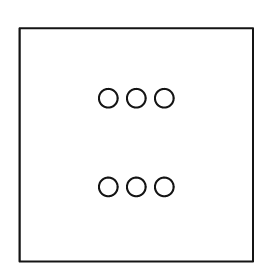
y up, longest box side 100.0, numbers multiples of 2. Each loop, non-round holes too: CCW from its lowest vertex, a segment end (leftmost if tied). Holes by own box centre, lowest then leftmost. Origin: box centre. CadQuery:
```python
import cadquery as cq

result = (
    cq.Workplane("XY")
    .moveTo(-50.0, -50.0)
    .lineTo(50.0, -50.0)
    .lineTo(50.0, 50.0)
    .lineTo(-50.0, 50.0)
    .close()
    .moveTo(-12.0, -18.0)
    .circle(4.0)
    .moveTo(0.0, -18.0)
    .circle(4.0)
    .moveTo(12.0, -18.0)
    .circle(4.0)
    .moveTo(-12.0, 20.0)
    .circle(4.0)
    .moveTo(0.0, 20.0)
    .circle(4.0)
    .moveTo(12.0, 20.0)
    .circle(4.0)
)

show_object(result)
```